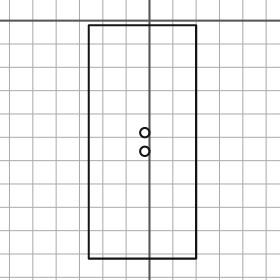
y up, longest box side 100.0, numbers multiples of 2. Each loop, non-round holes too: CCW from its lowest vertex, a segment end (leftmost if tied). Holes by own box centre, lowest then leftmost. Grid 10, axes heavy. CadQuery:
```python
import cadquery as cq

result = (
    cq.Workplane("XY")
    .moveTo(-26.0, -102.0)
    .lineTo(20.0, -102.0)
    .lineTo(20.0, -2.0)
    .lineTo(-26.0, -2.0)
    .close()
    .moveTo(-2.0, -56.0)
    .circle(2.0)
    .moveTo(-2.0, -48.0)
    .circle(2.0)
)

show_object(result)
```